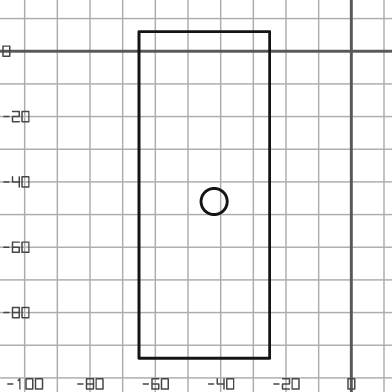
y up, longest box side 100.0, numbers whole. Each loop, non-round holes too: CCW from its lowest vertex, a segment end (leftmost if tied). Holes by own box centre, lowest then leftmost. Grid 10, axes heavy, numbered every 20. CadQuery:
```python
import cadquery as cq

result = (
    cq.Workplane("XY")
    .moveTo(-65.0, -94.0)
    .lineTo(-25.0, -94.0)
    .lineTo(-25.0, 6.0)
    .lineTo(-65.0, 6.0)
    .close()
    .moveTo(-42.0, -46.0)
    .circle(4.0)
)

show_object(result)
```